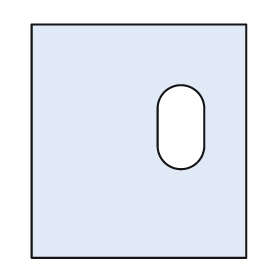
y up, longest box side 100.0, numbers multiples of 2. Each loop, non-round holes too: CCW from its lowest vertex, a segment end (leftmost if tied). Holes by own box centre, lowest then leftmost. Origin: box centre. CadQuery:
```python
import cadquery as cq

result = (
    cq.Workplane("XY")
    .moveTo(-46.0, -50.0)
    .lineTo(46.0, -50.0)
    .lineTo(46.0, 50.0)
    .lineTo(-46.0, 50.0)
    .close()
    .moveTo(8.0, -2.0)
    .threePointArc((18.0, -12.0), (28.0, -2.0))
    .lineTo(28.0, 14.0)
    .threePointArc((18.0, 24.0), (8.0, 14.0))
    .close()
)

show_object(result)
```